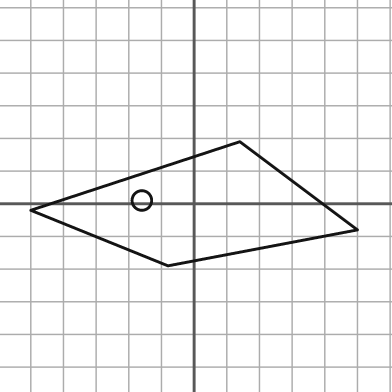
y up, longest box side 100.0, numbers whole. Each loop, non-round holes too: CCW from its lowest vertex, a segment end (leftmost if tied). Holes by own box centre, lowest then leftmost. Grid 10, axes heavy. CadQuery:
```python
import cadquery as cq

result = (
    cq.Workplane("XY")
    .moveTo(-8.0, -19.0)
    .lineTo(50.0, -8.0)
    .lineTo(14.0, 19.0)
    .lineTo(-50.0, -2.0)
    .close()
    .moveTo(-16.0, 1.0)
    .circle(3.0)
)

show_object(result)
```